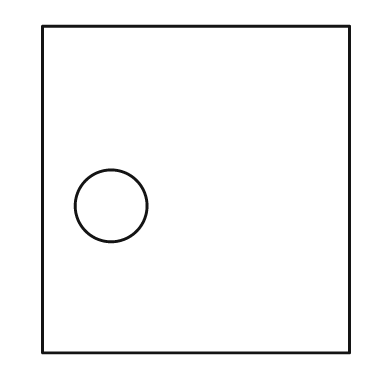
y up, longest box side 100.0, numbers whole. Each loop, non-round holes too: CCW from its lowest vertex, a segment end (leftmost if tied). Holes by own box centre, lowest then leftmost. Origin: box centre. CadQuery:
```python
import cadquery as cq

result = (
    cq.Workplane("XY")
    .moveTo(-47.0, -50.0)
    .lineTo(47.0, -50.0)
    .lineTo(47.0, 50.0)
    .lineTo(-47.0, 50.0)
    .close()
    .moveTo(-26.0, -5.0)
    .circle(11.0)
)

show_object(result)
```